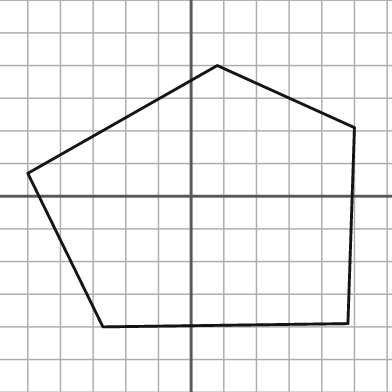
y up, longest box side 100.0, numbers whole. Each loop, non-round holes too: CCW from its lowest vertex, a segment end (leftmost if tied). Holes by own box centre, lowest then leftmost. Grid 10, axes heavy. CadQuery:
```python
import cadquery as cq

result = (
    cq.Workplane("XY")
    .moveTo(-27.0, -40.0)
    .lineTo(48.0, -39.0)
    .lineTo(50.0, 21.0)
    .lineTo(8.0, 40.0)
    .lineTo(-50.0, 7.0)
    .close()
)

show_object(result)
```